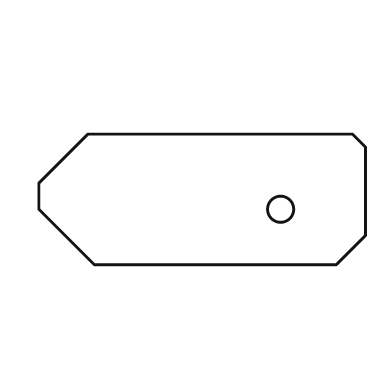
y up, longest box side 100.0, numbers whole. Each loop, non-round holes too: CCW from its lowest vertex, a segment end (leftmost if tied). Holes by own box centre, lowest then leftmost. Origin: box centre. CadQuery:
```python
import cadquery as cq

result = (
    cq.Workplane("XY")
    .moveTo(-33.0, -20.0)
    .lineTo(41.0, -20.0)
    .lineTo(50.0, -11.0)
    .lineTo(50.0, 16.0)
    .lineTo(46.0, 20.0)
    .lineTo(-35.0, 20.0)
    .lineTo(-50.0, 5.0)
    .lineTo(-50.0, -3.0)
    .close()
    .moveTo(24.0, -3.0)
    .circle(4.0)
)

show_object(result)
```